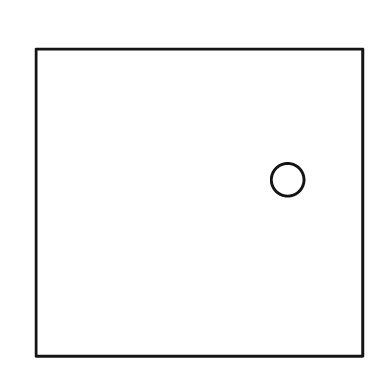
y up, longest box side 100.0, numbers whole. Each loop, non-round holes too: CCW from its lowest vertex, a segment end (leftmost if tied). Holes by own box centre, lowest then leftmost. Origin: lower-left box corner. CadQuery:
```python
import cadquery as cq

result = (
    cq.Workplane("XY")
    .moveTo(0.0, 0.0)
    .lineTo(100.0, 0.0)
    .lineTo(100.0, 94.0)
    .lineTo(0.0, 94.0)
    .close()
    .moveTo(77.0, 54.0)
    .circle(5.0)
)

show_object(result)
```